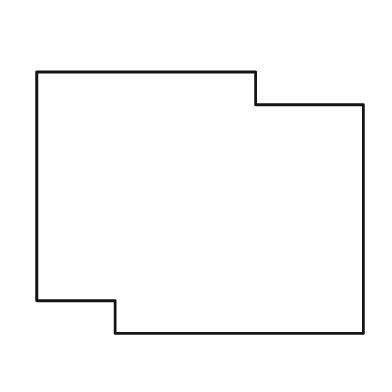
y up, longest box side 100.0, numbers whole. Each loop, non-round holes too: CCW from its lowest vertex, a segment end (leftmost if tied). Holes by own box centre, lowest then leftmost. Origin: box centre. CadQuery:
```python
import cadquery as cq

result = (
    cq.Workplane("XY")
    .moveTo(-26.0, -40.0)
    .lineTo(50.0, -40.0)
    .lineTo(50.0, 30.0)
    .lineTo(17.0, 30.0)
    .lineTo(17.0, 40.0)
    .lineTo(-50.0, 40.0)
    .lineTo(-50.0, -30.0)
    .lineTo(-26.0, -30.0)
    .close()
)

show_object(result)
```